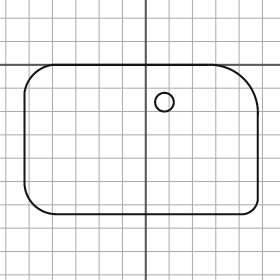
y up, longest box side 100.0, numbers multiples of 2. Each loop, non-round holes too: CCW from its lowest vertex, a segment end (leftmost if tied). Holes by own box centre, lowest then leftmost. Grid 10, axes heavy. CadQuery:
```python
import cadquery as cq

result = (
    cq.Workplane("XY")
    .moveTo(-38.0, -64.0)
    .lineTo(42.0, -64.0)
    .threePointArc((46.0, -62.0), (48.0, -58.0))
    .lineTo(48.0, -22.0)
    .threePointArc((42.0, -6.0), (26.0, 0.0))
    .lineTo(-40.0, 0.0)
    .threePointArc((-48.0, -4.0), (-52.0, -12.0))
    .lineTo(-52.0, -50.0)
    .threePointArc((-48.0, -60.0), (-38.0, -64.0))
    .close()
    .moveTo(8.0, -16.0)
    .circle(4.0)
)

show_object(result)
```